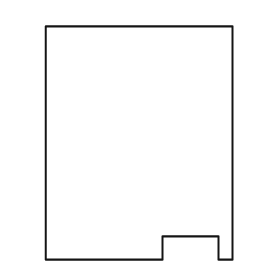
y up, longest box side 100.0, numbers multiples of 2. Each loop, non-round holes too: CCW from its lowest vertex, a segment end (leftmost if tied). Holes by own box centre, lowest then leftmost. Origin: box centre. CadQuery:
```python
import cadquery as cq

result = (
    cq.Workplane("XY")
    .moveTo(-40.0, -50.0)
    .lineTo(10.0, -50.0)
    .lineTo(10.0, -40.0)
    .lineTo(34.0, -40.0)
    .lineTo(34.0, -50.0)
    .lineTo(40.0, -50.0)
    .lineTo(40.0, 50.0)
    .lineTo(-40.0, 50.0)
    .close()
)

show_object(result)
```